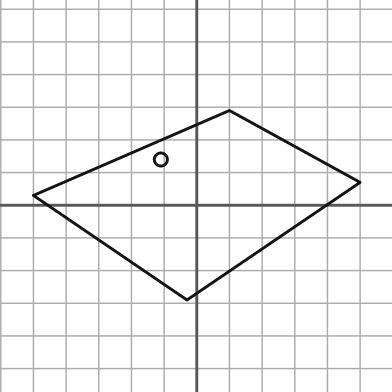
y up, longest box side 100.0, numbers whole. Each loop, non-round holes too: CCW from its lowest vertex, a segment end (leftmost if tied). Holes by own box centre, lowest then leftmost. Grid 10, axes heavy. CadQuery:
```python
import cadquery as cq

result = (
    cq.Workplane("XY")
    .moveTo(-3.0, -29.0)
    .lineTo(50.0, 7.0)
    .lineTo(10.0, 29.0)
    .lineTo(-50.0, 3.0)
    .close()
    .moveTo(-11.0, 14.0)
    .circle(2.0)
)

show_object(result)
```